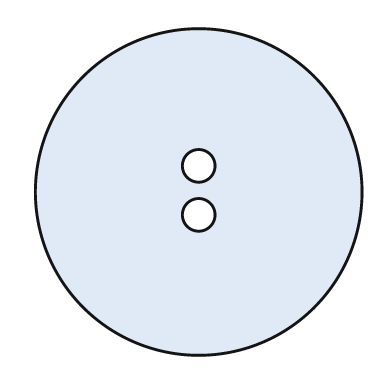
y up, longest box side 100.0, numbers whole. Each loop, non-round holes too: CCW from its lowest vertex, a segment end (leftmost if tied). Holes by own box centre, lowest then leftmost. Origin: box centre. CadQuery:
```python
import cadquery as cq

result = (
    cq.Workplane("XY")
    .moveTo(0.0, 0.0)
    .circle(50.0)
    .moveTo(0.0, -7.0)
    .circle(5.0)
    .moveTo(0.0, 8.0)
    .circle(5.0)
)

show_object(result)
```